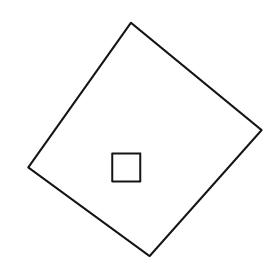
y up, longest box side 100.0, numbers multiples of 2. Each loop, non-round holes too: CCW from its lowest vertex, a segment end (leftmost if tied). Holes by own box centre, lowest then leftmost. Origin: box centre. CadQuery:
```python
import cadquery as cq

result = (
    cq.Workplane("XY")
    .moveTo(2.0, -50.0)
    .lineTo(50.0, 4.0)
    .lineTo(-6.0, 50.0)
    .lineTo(-50.0, -12.0)
    .close()
    .moveTo(-14.0, -18.0)
    .lineTo(-2.0, -18.0)
    .lineTo(-2.0, -6.0)
    .lineTo(-14.0, -6.0)
    .close()
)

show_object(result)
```